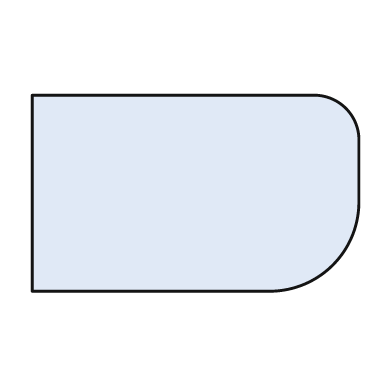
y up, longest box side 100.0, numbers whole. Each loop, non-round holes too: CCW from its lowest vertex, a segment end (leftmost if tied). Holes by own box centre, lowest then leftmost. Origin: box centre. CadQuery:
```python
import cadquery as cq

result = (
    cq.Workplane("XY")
    .moveTo(-50.0, -30.0)
    .lineTo(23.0, -30.0)
    .threePointArc((42.0, -22.0), (50.0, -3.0))
    .lineTo(50.0, 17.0)
    .threePointArc((46.0, 26.0), (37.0, 30.0))
    .lineTo(-50.0, 30.0)
    .close()
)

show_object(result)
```